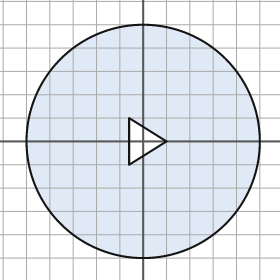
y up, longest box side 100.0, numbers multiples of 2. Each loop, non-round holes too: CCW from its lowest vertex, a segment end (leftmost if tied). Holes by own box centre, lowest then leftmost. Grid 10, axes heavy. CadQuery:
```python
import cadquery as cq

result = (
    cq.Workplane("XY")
    .moveTo(0.0, 0.0)
    .circle(50.0)
    .moveTo(-6.0, -10.0)
    .lineTo(10.0, 0.0)
    .lineTo(-6.0, 10.0)
    .close()
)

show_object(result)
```